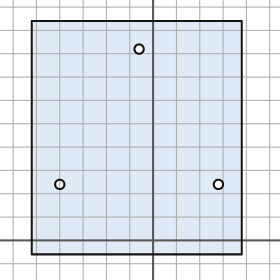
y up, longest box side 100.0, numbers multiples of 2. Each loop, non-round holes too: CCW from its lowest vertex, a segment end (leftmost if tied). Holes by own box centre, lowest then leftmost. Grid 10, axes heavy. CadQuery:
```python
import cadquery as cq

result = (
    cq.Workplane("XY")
    .moveTo(-52.0, -6.0)
    .lineTo(38.0, -6.0)
    .lineTo(38.0, 94.0)
    .lineTo(-52.0, 94.0)
    .close()
    .moveTo(-40.0, 24.0)
    .circle(2.0)
    .moveTo(28.0, 24.0)
    .circle(2.0)
    .moveTo(-6.0, 82.0)
    .circle(2.0)
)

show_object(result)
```